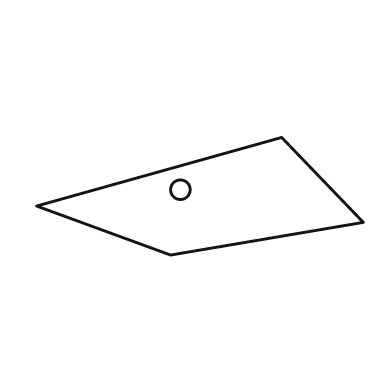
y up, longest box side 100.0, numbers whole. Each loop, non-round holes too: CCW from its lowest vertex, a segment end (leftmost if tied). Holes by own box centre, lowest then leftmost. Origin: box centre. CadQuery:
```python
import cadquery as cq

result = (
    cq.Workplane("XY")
    .moveTo(-9.0, -18.0)
    .lineTo(50.0, -8.0)
    .lineTo(25.0, 18.0)
    .lineTo(-50.0, -3.0)
    .close()
    .moveTo(-6.0, 2.0)
    .circle(3.0)
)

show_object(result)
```